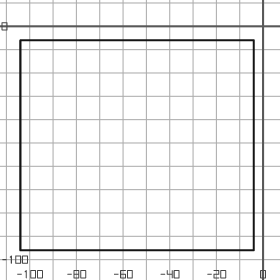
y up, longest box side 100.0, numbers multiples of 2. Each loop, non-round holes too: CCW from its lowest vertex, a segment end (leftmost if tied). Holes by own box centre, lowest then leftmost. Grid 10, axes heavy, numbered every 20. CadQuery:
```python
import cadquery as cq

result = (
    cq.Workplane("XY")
    .moveTo(-104.0, -96.0)
    .lineTo(-4.0, -96.0)
    .lineTo(-4.0, -6.0)
    .lineTo(-104.0, -6.0)
    .close()
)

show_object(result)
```